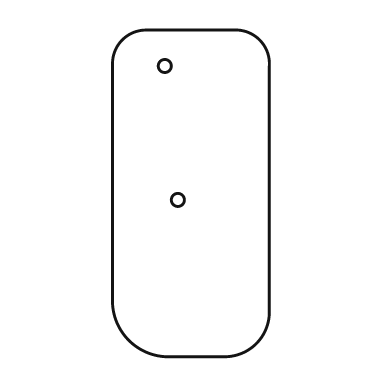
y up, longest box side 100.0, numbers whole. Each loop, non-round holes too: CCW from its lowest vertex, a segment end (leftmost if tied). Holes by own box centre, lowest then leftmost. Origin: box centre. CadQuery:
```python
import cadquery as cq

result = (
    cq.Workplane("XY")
    .moveTo(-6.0, -50.0)
    .lineTo(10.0, -50.0)
    .threePointArc((20.0, -46.0), (24.0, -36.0))
    .lineTo(24.0, 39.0)
    .threePointArc((21.0, 47.0), (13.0, 50.0))
    .lineTo(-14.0, 50.0)
    .threePointArc((-21.0, 47.0), (-24.0, 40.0))
    .lineTo(-24.0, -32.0)
    .threePointArc((-19.0, -45.0), (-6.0, -50.0))
    .close()
    .moveTo(-4.0, -2.0)
    .circle(2.0)
    .moveTo(-8.0, 39.0)
    .circle(2.0)
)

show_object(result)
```